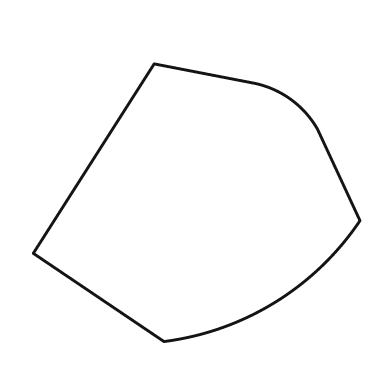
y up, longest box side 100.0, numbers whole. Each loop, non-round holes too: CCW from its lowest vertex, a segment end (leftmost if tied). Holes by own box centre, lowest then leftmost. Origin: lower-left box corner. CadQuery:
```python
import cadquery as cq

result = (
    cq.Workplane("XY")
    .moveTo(40.0, 0.0)
    .threePointArc((74.0, 12.0), (100.0, 37.0))
    .lineTo(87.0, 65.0)
    .threePointArc((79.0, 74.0), (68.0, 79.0))
    .lineTo(37.0, 85.0)
    .lineTo(0.0, 27.0)
    .close()
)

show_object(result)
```